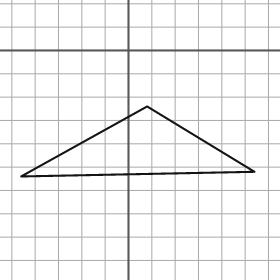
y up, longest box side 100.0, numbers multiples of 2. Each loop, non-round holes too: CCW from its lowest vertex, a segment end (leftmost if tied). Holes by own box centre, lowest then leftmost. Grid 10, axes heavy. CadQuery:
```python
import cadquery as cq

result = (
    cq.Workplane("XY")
    .moveTo(-46.0, -54.0)
    .lineTo(54.0, -52.0)
    .lineTo(8.0, -24.0)
    .close()
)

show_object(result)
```